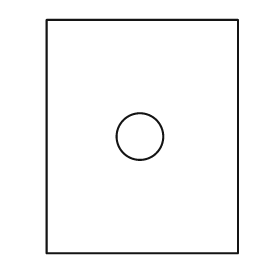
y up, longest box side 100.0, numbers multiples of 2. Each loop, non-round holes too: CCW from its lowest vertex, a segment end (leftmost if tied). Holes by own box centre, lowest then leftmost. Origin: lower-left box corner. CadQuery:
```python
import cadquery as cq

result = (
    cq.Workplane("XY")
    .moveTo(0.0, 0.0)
    .lineTo(82.0, 0.0)
    .lineTo(82.0, 100.0)
    .lineTo(0.0, 100.0)
    .close()
    .moveTo(40.0, 50.0)
    .circle(10.0)
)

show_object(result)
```